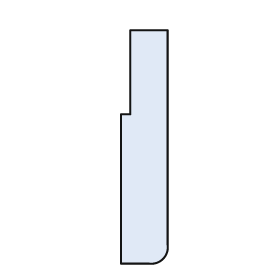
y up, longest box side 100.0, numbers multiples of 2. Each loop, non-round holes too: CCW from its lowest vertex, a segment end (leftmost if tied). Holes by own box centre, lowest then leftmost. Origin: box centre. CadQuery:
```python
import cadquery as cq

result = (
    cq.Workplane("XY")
    .moveTo(-10.0, -50.0)
    .lineTo(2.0, -50.0)
    .threePointArc((8.0, -48.0), (10.0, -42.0))
    .lineTo(10.0, 50.0)
    .lineTo(-6.0, 50.0)
    .lineTo(-6.0, 14.0)
    .lineTo(-10.0, 14.0)
    .close()
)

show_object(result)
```